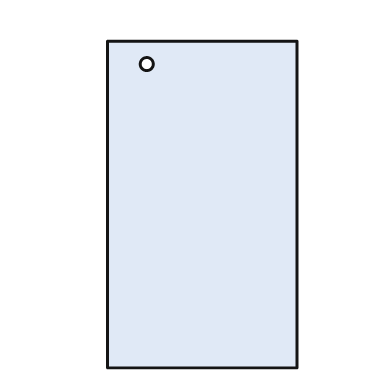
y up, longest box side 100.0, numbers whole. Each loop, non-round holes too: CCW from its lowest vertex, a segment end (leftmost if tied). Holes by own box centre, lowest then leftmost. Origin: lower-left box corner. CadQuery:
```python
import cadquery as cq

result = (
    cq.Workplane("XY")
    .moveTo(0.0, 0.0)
    .lineTo(58.0, 0.0)
    .lineTo(58.0, 100.0)
    .lineTo(0.0, 100.0)
    .close()
    .moveTo(12.0, 93.0)
    .circle(2.0)
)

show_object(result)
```